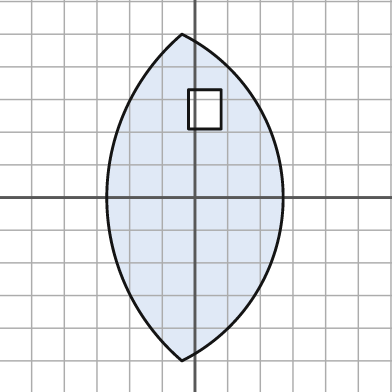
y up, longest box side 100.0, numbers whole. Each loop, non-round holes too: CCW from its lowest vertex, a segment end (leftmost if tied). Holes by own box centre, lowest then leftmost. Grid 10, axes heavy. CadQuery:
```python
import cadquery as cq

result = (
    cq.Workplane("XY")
    .moveTo(-4.0, -50.0)
    .threePointArc((27.0, 0.0), (-4.0, 50.0))
    .threePointArc((-27.0, 0.0), (-4.0, -50.0))
    .close()
    .moveTo(-2.0, 21.0)
    .lineTo(8.0, 21.0)
    .lineTo(8.0, 33.0)
    .lineTo(-2.0, 33.0)
    .close()
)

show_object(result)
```